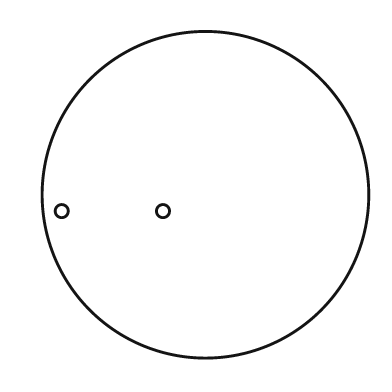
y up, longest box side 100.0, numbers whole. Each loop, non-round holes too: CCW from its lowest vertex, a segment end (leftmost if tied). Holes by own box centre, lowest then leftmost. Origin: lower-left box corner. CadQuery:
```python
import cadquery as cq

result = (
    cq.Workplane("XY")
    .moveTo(50.0, 50.0)
    .circle(50.0)
    .moveTo(6.0, 45.0)
    .circle(2.0)
    .moveTo(37.0, 45.0)
    .circle(2.0)
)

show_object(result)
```